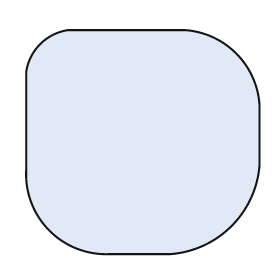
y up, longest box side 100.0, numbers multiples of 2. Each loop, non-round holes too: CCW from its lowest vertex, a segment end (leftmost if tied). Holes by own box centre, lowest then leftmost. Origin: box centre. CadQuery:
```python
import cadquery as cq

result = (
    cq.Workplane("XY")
    .moveTo(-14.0, -48.0)
    .lineTo(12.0, -48.0)
    .threePointArc((38.0, -36.0), (50.0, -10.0))
    .lineTo(50.0, 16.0)
    .threePointArc((40.0, 38.0), (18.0, 48.0))
    .lineTo(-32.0, 48.0)
    .threePointArc((-44.0, 42.0), (-50.0, 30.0))
    .lineTo(-50.0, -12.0)
    .threePointArc((-40.0, -38.0), (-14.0, -48.0))
    .close()
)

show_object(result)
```